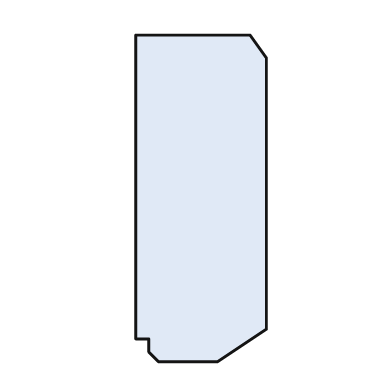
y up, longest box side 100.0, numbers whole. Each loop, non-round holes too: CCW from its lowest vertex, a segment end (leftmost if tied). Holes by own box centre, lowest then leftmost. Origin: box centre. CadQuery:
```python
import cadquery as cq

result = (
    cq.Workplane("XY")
    .moveTo(-13.0, -50.0)
    .lineTo(5.0, -50.0)
    .lineTo(20.0, -40.0)
    .lineTo(20.0, 43.0)
    .lineTo(15.0, 50.0)
    .lineTo(-20.0, 50.0)
    .lineTo(-20.0, -43.0)
    .lineTo(-16.0, -43.0)
    .lineTo(-16.0, -47.0)
    .close()
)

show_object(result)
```